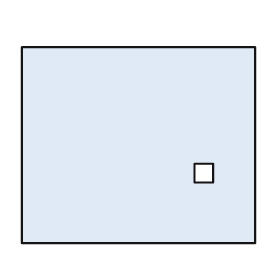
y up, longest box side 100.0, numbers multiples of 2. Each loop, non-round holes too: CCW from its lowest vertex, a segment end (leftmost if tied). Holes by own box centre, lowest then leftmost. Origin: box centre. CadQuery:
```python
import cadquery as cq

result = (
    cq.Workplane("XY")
    .moveTo(-50.0, -42.0)
    .lineTo(50.0, -42.0)
    .lineTo(50.0, 42.0)
    .lineTo(-50.0, 42.0)
    .close()
    .moveTo(24.0, -16.0)
    .lineTo(32.0, -16.0)
    .lineTo(32.0, -8.0)
    .lineTo(24.0, -8.0)
    .close()
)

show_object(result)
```